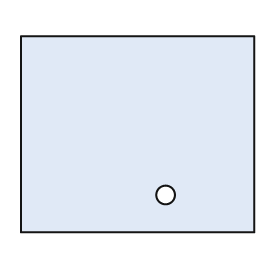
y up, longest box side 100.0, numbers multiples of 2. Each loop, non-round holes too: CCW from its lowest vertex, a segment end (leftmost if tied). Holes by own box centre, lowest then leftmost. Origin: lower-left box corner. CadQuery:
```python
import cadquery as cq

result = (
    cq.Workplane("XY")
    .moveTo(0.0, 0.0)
    .lineTo(100.0, 0.0)
    .lineTo(100.0, 84.0)
    .lineTo(0.0, 84.0)
    .close()
    .moveTo(62.0, 16.0)
    .circle(4.0)
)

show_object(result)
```